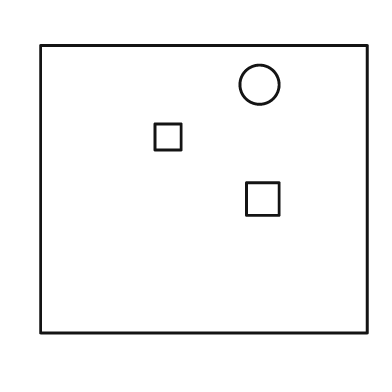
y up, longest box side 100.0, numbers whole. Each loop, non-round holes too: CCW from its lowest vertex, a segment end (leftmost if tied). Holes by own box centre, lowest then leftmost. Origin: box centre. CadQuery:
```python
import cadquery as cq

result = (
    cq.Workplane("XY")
    .moveTo(-50.0, -44.0)
    .lineTo(50.0, -44.0)
    .lineTo(50.0, 44.0)
    .lineTo(-50.0, 44.0)
    .close()
    .moveTo(13.0, -8.0)
    .lineTo(23.0, -8.0)
    .lineTo(23.0, 2.0)
    .lineTo(13.0, 2.0)
    .close()
    .moveTo(-15.0, 12.0)
    .lineTo(-7.0, 12.0)
    .lineTo(-7.0, 20.0)
    .lineTo(-15.0, 20.0)
    .close()
    .moveTo(17.0, 32.0)
    .circle(6.0)
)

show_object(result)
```